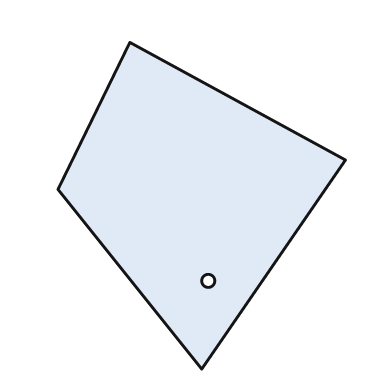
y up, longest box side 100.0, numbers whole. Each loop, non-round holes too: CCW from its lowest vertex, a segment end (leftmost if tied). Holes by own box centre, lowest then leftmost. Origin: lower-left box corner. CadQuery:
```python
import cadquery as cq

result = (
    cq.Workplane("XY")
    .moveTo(44.0, 0.0)
    .lineTo(88.0, 64.0)
    .lineTo(22.0, 100.0)
    .lineTo(0.0, 55.0)
    .close()
    .moveTo(46.0, 27.0)
    .circle(2.0)
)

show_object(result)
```